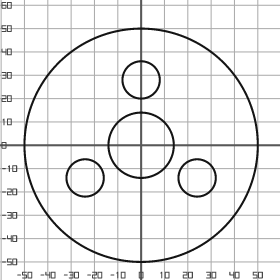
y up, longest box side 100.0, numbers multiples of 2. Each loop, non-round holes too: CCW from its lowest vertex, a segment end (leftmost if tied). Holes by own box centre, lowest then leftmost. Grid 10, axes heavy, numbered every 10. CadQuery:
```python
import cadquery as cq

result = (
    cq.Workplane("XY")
    .moveTo(0.0, 0.0)
    .circle(50.0)
    .moveTo(-24.0, -14.0)
    .circle(8.0)
    .moveTo(24.0, -14.0)
    .circle(8.0)
    .moveTo(0.0, 0.0)
    .circle(14.0)
    .moveTo(0.0, 28.0)
    .circle(8.0)
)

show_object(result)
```